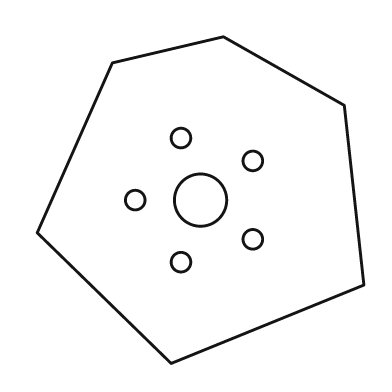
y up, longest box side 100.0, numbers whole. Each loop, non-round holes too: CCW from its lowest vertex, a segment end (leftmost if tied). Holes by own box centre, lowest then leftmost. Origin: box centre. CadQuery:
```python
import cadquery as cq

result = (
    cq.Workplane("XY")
    .moveTo(-9.0, -50.0)
    .lineTo(50.0, -26.0)
    .lineTo(44.0, 29.0)
    .lineTo(7.0, 50.0)
    .lineTo(-27.0, 42.0)
    .lineTo(-50.0, -10.0)
    .close()
    .moveTo(-6.0, -19.0)
    .circle(3.0)
    .moveTo(16.0, -12.0)
    .circle(3.0)
    .moveTo(-20.0, 0.0)
    .circle(3.0)
    .moveTo(0.0, 0.0)
    .circle(8.0)
    .moveTo(16.0, 12.0)
    .circle(3.0)
    .moveTo(-6.0, 19.0)
    .circle(3.0)
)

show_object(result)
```